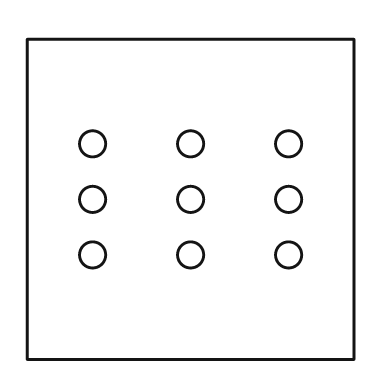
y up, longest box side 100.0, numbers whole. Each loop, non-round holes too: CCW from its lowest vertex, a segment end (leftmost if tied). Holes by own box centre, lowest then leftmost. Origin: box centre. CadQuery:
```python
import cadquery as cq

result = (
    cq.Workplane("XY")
    .moveTo(-50.0, -49.0)
    .lineTo(50.0, -49.0)
    .lineTo(50.0, 49.0)
    .lineTo(-50.0, 49.0)
    .close()
    .moveTo(-30.0, -17.0)
    .circle(4.0)
    .moveTo(0.0, -17.0)
    .circle(4.0)
    .moveTo(30.0, -17.0)
    .circle(4.0)
    .moveTo(-30.0, 0.0)
    .circle(4.0)
    .moveTo(0.0, 0.0)
    .circle(4.0)
    .moveTo(30.0, 0.0)
    .circle(4.0)
    .moveTo(-30.0, 17.0)
    .circle(4.0)
    .moveTo(0.0, 17.0)
    .circle(4.0)
    .moveTo(30.0, 17.0)
    .circle(4.0)
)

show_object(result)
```